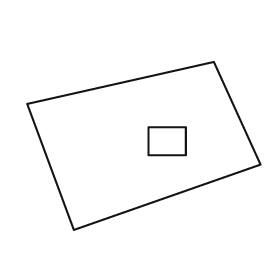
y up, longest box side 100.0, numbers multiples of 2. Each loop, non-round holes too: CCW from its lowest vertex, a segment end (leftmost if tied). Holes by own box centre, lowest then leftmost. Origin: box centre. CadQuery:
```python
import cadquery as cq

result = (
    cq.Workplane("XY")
    .moveTo(-30.0, -36.0)
    .lineTo(50.0, -8.0)
    .lineTo(30.0, 36.0)
    .lineTo(-50.0, 18.0)
    .close()
    .moveTo(2.0, -4.0)
    .lineTo(18.0, -4.0)
    .lineTo(18.0, 8.0)
    .lineTo(2.0, 8.0)
    .close()
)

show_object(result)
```